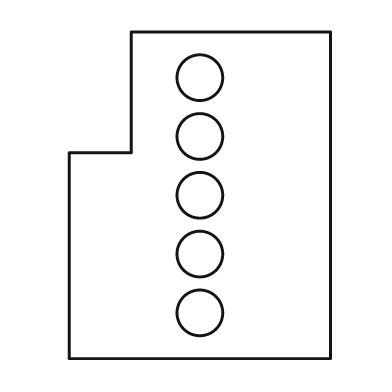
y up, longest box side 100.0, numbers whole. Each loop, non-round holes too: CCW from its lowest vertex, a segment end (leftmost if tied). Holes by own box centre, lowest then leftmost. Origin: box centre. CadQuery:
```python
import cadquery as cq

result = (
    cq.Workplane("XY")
    .moveTo(-40.0, -50.0)
    .lineTo(40.0, -50.0)
    .lineTo(40.0, 50.0)
    .lineTo(-21.0, 50.0)
    .lineTo(-21.0, 13.0)
    .lineTo(-40.0, 13.0)
    .close()
    .moveTo(0.0, -36.0)
    .circle(7.0)
    .moveTo(0.0, -18.0)
    .circle(7.0)
    .moveTo(0.0, 0.0)
    .circle(7.0)
    .moveTo(0.0, 18.0)
    .circle(7.0)
    .moveTo(0.0, 36.0)
    .circle(7.0)
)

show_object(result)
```